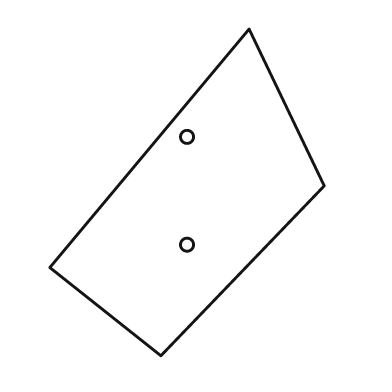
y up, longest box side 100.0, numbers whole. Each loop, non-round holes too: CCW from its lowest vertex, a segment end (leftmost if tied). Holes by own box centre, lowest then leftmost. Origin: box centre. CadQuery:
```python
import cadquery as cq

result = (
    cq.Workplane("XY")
    .moveTo(-8.0, -50.0)
    .lineTo(42.0, 2.0)
    .lineTo(19.0, 50.0)
    .lineTo(-42.0, -23.0)
    .close()
    .moveTo(0.0, -16.0)
    .circle(2.0)
    .moveTo(0.0, 17.0)
    .circle(2.0)
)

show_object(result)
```